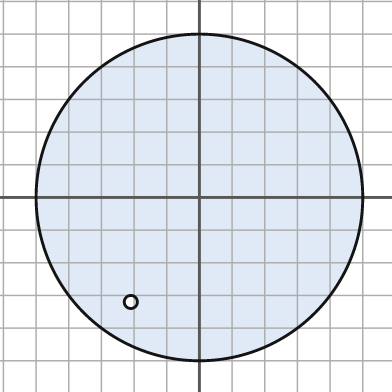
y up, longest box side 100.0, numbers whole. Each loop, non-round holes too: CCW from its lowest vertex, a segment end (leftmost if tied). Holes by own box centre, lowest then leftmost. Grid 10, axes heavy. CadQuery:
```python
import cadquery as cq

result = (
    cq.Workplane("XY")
    .moveTo(0.0, 0.0)
    .circle(50.0)
    .moveTo(-21.0, -32.0)
    .circle(2.0)
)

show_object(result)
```